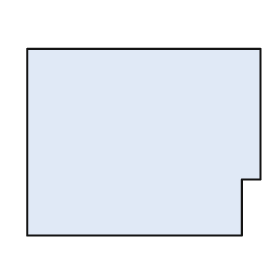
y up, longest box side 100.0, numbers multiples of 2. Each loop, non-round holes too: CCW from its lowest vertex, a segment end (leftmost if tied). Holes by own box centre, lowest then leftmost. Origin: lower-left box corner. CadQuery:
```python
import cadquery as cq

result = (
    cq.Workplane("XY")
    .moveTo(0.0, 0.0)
    .lineTo(92.0, 0.0)
    .lineTo(92.0, 24.0)
    .lineTo(100.0, 24.0)
    .lineTo(100.0, 80.0)
    .lineTo(0.0, 80.0)
    .close()
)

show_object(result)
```